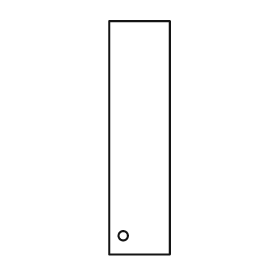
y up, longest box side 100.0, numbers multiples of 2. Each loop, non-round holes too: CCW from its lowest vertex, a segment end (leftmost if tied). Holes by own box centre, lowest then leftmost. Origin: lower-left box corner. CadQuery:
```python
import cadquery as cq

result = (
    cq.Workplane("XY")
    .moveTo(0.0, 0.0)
    .lineTo(26.0, 0.0)
    .lineTo(26.0, 100.0)
    .lineTo(0.0, 100.0)
    .close()
    .moveTo(6.0, 8.0)
    .circle(2.0)
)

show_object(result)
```